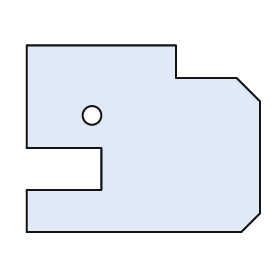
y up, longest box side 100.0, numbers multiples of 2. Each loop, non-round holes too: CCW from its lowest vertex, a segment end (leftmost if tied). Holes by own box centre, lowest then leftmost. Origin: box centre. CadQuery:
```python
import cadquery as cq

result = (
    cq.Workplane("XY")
    .moveTo(-50.0, -40.0)
    .lineTo(42.0, -40.0)
    .lineTo(50.0, -32.0)
    .lineTo(50.0, 16.0)
    .lineTo(40.0, 26.0)
    .lineTo(14.0, 26.0)
    .lineTo(14.0, 40.0)
    .lineTo(-50.0, 40.0)
    .lineTo(-50.0, -4.0)
    .lineTo(-18.0, -4.0)
    .lineTo(-18.0, -22.0)
    .lineTo(-50.0, -22.0)
    .close()
    .moveTo(-22.0, 10.0)
    .circle(4.0)
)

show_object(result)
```